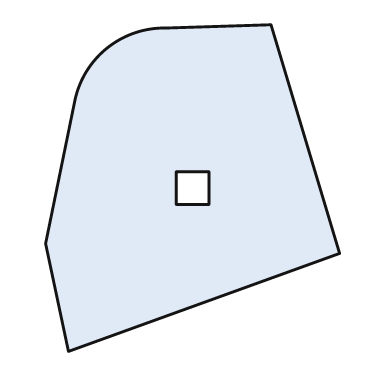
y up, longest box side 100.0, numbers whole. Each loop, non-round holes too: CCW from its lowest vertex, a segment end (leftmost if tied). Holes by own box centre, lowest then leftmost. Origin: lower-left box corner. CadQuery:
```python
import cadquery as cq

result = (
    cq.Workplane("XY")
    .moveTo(7.0, 0.0)
    .lineTo(90.0, 30.0)
    .lineTo(69.0, 100.0)
    .lineTo(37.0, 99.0)
    .threePointArc((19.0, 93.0), (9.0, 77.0))
    .lineTo(0.0, 33.0)
    .close()
    .moveTo(40.0, 45.0)
    .lineTo(50.0, 45.0)
    .lineTo(50.0, 55.0)
    .lineTo(40.0, 55.0)
    .close()
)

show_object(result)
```